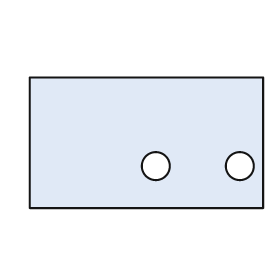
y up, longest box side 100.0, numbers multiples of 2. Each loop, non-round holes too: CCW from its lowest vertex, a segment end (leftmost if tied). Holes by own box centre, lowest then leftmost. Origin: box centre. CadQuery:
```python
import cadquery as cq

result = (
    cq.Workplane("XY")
    .moveTo(-50.0, -28.0)
    .lineTo(50.0, -28.0)
    .lineTo(50.0, 28.0)
    .lineTo(-50.0, 28.0)
    .close()
    .moveTo(4.0, -10.0)
    .circle(6.0)
    .moveTo(40.0, -10.0)
    .circle(6.0)
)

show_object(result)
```